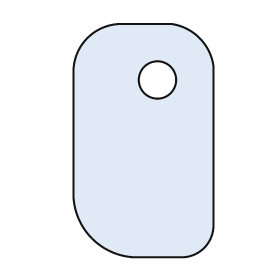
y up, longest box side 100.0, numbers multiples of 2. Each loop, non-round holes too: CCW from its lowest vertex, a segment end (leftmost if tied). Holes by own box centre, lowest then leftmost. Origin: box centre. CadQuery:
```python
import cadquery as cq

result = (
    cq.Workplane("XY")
    .moveTo(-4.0, -50.0)
    .lineTo(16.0, -50.0)
    .threePointArc((26.0, -46.0), (30.0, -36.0))
    .lineTo(30.0, 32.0)
    .threePointArc((24.0, 44.0), (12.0, 50.0))
    .lineTo(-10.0, 50.0)
    .threePointArc((-24.0, 44.0), (-30.0, 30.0))
    .lineTo(-30.0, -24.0)
    .threePointArc((-22.0, -42.0), (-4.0, -50.0))
    .close()
    .moveTo(6.0, 26.0)
    .circle(8.0)
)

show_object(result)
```